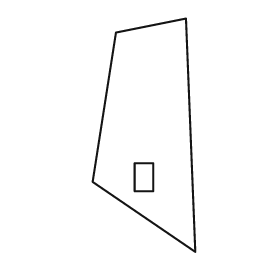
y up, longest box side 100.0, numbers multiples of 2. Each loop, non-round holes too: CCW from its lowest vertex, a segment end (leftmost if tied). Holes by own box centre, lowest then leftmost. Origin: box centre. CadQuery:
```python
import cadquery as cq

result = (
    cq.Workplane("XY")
    .moveTo(22.0, -50.0)
    .lineTo(18.0, 50.0)
    .lineTo(-12.0, 44.0)
    .lineTo(-22.0, -20.0)
    .close()
    .moveTo(-4.0, -24.0)
    .lineTo(4.0, -24.0)
    .lineTo(4.0, -12.0)
    .lineTo(-4.0, -12.0)
    .close()
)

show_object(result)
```